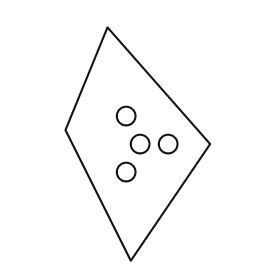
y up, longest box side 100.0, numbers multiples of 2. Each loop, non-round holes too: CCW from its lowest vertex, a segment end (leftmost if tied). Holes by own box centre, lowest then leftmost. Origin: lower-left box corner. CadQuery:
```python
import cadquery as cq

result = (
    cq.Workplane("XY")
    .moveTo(28.0, 0.0)
    .lineTo(62.0, 50.0)
    .lineTo(18.0, 100.0)
    .lineTo(0.0, 56.0)
    .close()
    .moveTo(26.0, 38.0)
    .circle(4.0)
    .moveTo(32.0, 50.0)
    .circle(4.0)
    .moveTo(44.0, 50.0)
    .circle(4.0)
    .moveTo(26.0, 62.0)
    .circle(4.0)
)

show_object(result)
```